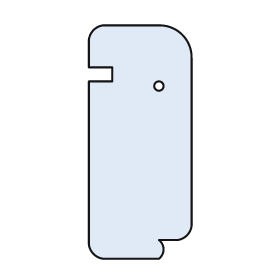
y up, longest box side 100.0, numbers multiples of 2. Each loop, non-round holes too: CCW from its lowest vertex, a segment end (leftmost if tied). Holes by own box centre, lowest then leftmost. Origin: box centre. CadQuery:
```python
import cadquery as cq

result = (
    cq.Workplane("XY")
    .moveTo(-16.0, -50.0)
    .lineTo(8.0, -50.0)
    .threePointArc((10.0, -46.0), (8.0, -42.0))
    .lineTo(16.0, -42.0)
    .threePointArc((20.0, -40.0), (22.0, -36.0))
    .lineTo(22.0, 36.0)
    .threePointArc((18.0, 46.0), (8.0, 50.0))
    .lineTo(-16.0, 50.0)
    .threePointArc((-20.0, 48.0), (-22.0, 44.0))
    .lineTo(-22.0, 32.0)
    .lineTo(-12.0, 32.0)
    .lineTo(-12.0, 26.0)
    .lineTo(-22.0, 26.0)
    .lineTo(-22.0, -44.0)
    .threePointArc((-20.0, -48.0), (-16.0, -50.0))
    .close()
    .moveTo(8.0, 24.0)
    .circle(2.0)
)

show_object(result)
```